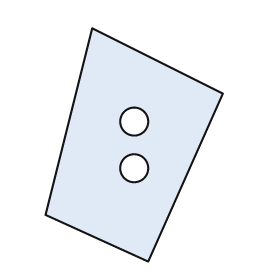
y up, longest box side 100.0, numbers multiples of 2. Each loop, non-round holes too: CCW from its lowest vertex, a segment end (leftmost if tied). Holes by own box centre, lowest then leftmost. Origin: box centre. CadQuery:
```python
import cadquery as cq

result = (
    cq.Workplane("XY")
    .moveTo(6.0, -50.0)
    .lineTo(38.0, 22.0)
    .lineTo(-18.0, 50.0)
    .lineTo(-38.0, -30.0)
    .close()
    .moveTo(0.0, -10.0)
    .circle(6.0)
    .moveTo(0.0, 10.0)
    .circle(6.0)
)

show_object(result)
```